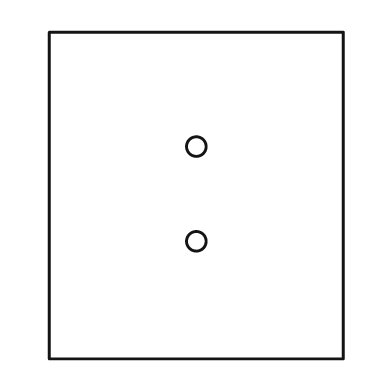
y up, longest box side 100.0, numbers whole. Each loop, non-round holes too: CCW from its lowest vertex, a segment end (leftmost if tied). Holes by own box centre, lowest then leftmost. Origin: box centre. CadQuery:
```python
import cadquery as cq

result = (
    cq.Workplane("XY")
    .moveTo(-45.0, -50.0)
    .lineTo(45.0, -50.0)
    .lineTo(45.0, 50.0)
    .lineTo(-45.0, 50.0)
    .close()
    .moveTo(0.0, -14.0)
    .circle(3.0)
    .moveTo(0.0, 15.0)
    .circle(3.0)
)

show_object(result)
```